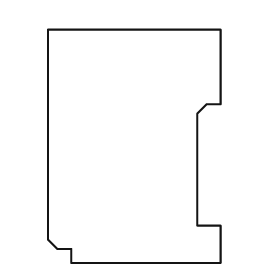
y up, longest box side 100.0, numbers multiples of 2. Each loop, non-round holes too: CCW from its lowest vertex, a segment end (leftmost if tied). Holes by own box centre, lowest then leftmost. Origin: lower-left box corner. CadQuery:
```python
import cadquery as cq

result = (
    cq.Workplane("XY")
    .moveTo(10.0, 0.0)
    .lineTo(74.0, 0.0)
    .lineTo(74.0, 16.0)
    .lineTo(64.0, 16.0)
    .lineTo(64.0, 64.0)
    .lineTo(68.0, 68.0)
    .lineTo(74.0, 68.0)
    .lineTo(74.0, 100.0)
    .lineTo(0.0, 100.0)
    .lineTo(0.0, 10.0)
    .lineTo(4.0, 6.0)
    .lineTo(10.0, 6.0)
    .close()
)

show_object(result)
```